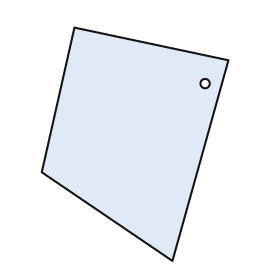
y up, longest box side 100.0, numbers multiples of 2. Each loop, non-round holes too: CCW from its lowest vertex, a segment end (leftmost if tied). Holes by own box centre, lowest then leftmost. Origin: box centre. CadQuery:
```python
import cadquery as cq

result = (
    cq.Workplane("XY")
    .moveTo(16.0, -50.0)
    .lineTo(40.0, 36.0)
    .lineTo(-26.0, 50.0)
    .lineTo(-40.0, -12.0)
    .close()
    .moveTo(30.0, 26.0)
    .circle(2.0)
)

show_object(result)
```